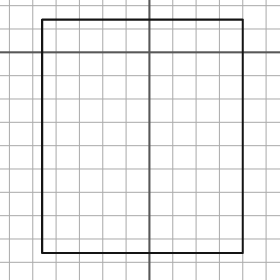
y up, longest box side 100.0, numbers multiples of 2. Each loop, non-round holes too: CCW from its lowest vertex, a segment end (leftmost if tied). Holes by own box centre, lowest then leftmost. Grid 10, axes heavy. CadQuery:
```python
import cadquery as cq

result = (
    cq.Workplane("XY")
    .moveTo(-46.0, -86.0)
    .lineTo(40.0, -86.0)
    .lineTo(40.0, 14.0)
    .lineTo(-46.0, 14.0)
    .close()
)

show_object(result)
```